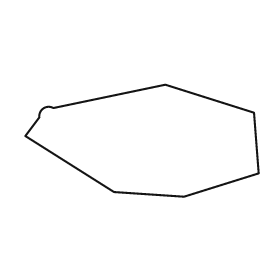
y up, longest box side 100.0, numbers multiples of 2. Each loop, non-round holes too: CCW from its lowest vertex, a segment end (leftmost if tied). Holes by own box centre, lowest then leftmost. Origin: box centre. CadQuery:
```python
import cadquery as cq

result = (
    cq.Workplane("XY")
    .moveTo(18.0, -24.0)
    .lineTo(50.0, -14.0)
    .lineTo(48.0, 12.0)
    .lineTo(10.0, 24.0)
    .lineTo(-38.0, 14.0)
    .threePointArc((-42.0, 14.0), (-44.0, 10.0))
    .lineTo(-50.0, 2.0)
    .lineTo(-12.0, -22.0)
    .close()
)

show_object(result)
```